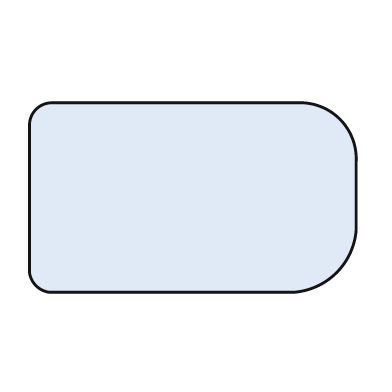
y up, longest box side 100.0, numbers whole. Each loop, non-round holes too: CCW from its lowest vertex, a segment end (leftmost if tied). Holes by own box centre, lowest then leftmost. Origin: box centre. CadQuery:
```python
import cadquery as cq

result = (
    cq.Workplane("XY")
    .moveTo(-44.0, -29.0)
    .lineTo(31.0, -29.0)
    .threePointArc((44.0, -23.0), (50.0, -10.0))
    .lineTo(50.0, 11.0)
    .threePointArc((45.0, 24.0), (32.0, 29.0))
    .lineTo(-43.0, 29.0)
    .threePointArc((-48.0, 27.0), (-50.0, 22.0))
    .lineTo(-50.0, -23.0)
    .threePointArc((-48.0, -27.0), (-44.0, -29.0))
    .close()
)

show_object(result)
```